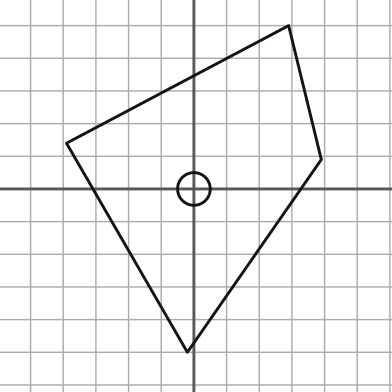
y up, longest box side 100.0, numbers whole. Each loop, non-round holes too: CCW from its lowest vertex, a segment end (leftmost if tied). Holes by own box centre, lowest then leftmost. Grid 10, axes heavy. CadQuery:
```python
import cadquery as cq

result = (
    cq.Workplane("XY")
    .moveTo(-2.0, -50.0)
    .lineTo(39.0, 9.0)
    .lineTo(29.0, 50.0)
    .lineTo(-39.0, 14.0)
    .close()
    .moveTo(0.0, 0.0)
    .circle(5.0)
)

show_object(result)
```